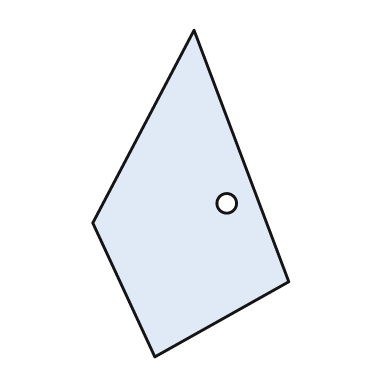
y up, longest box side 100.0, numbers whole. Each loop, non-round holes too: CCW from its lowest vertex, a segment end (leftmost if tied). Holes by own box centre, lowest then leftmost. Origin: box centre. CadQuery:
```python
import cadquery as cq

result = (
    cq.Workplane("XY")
    .moveTo(-11.0, -50.0)
    .lineTo(30.0, -27.0)
    .lineTo(1.0, 50.0)
    .lineTo(-30.0, -9.0)
    .close()
    .moveTo(11.0, -3.0)
    .circle(3.0)
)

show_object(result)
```